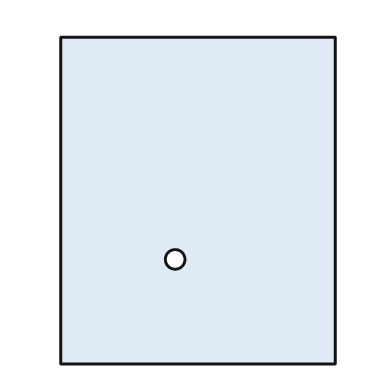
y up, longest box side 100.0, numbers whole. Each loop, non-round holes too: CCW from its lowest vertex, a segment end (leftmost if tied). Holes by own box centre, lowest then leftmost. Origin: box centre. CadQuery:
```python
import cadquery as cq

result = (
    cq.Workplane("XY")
    .moveTo(-42.0, -50.0)
    .lineTo(42.0, -50.0)
    .lineTo(42.0, 50.0)
    .lineTo(-42.0, 50.0)
    .close()
    .moveTo(-7.0, -18.0)
    .circle(3.0)
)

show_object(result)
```